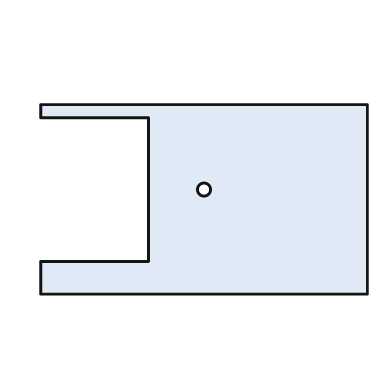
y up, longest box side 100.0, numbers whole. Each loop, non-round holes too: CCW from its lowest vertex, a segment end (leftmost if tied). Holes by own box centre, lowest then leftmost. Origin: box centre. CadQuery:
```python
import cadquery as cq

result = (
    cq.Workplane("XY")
    .moveTo(-50.0, -29.0)
    .lineTo(50.0, -29.0)
    .lineTo(50.0, 29.0)
    .lineTo(-50.0, 29.0)
    .lineTo(-50.0, 25.0)
    .lineTo(-17.0, 25.0)
    .lineTo(-17.0, -19.0)
    .lineTo(-50.0, -19.0)
    .close()
    .moveTo(0.0, 3.0)
    .circle(2.0)
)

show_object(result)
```